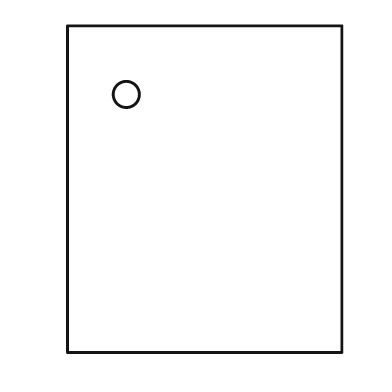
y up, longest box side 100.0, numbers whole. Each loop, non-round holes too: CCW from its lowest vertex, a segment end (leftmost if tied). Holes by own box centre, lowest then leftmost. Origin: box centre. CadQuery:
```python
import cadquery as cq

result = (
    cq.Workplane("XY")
    .moveTo(-42.0, -50.0)
    .lineTo(42.0, -50.0)
    .lineTo(42.0, 50.0)
    .lineTo(-42.0, 50.0)
    .close()
    .moveTo(-24.0, 29.0)
    .circle(4.0)
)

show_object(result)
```